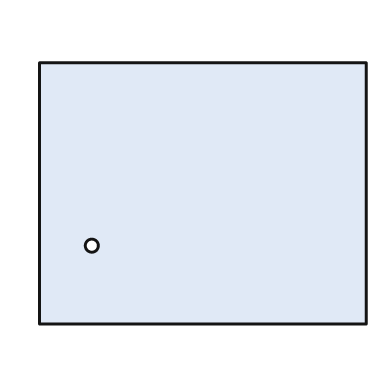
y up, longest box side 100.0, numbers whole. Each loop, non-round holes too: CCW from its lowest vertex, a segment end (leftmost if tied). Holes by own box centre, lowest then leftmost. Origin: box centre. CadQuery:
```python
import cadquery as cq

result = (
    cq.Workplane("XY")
    .moveTo(-50.0, -40.0)
    .lineTo(50.0, -40.0)
    .lineTo(50.0, 40.0)
    .lineTo(-50.0, 40.0)
    .close()
    .moveTo(-34.0, -16.0)
    .circle(2.0)
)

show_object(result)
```